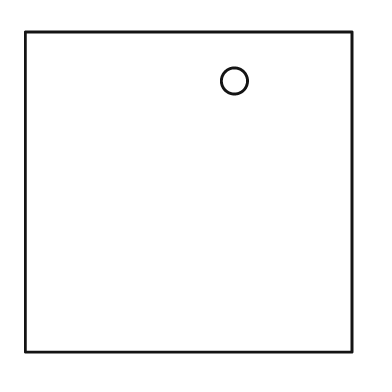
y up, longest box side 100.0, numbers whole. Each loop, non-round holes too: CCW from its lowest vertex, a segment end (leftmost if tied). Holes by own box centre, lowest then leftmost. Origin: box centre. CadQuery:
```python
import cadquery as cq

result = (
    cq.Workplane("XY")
    .moveTo(-50.0, -49.0)
    .lineTo(50.0, -49.0)
    .lineTo(50.0, 49.0)
    .lineTo(-50.0, 49.0)
    .close()
    .moveTo(14.0, 34.0)
    .circle(4.0)
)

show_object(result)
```